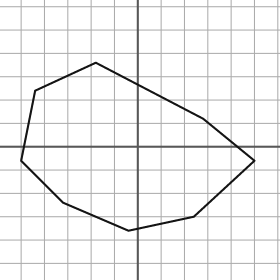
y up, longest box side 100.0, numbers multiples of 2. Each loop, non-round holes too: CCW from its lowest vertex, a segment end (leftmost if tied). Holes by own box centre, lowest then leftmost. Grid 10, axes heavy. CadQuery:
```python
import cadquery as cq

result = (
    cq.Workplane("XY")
    .moveTo(-4.0, -36.0)
    .lineTo(24.0, -30.0)
    .lineTo(50.0, -6.0)
    .lineTo(28.0, 12.0)
    .lineTo(-18.0, 36.0)
    .lineTo(-44.0, 24.0)
    .lineTo(-50.0, -6.0)
    .lineTo(-32.0, -24.0)
    .close()
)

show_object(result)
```